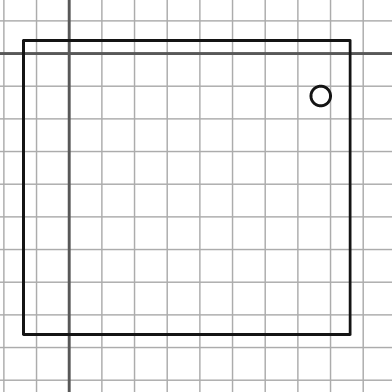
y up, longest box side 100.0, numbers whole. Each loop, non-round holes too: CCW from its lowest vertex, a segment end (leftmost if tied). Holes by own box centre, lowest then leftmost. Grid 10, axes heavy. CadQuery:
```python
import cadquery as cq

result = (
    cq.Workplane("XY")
    .moveTo(-14.0, -86.0)
    .lineTo(86.0, -86.0)
    .lineTo(86.0, 4.0)
    .lineTo(-14.0, 4.0)
    .close()
    .moveTo(77.0, -13.0)
    .circle(3.0)
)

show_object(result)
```